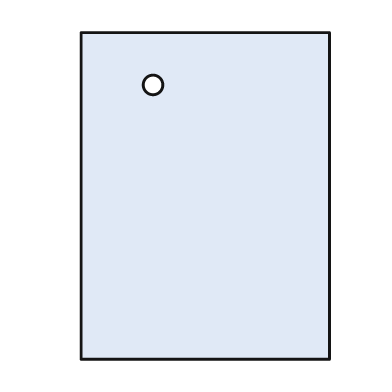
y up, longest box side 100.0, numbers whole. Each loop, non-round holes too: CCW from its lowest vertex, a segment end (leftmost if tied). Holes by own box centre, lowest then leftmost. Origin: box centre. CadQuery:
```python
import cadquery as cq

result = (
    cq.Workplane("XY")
    .moveTo(-38.0, -50.0)
    .lineTo(38.0, -50.0)
    .lineTo(38.0, 50.0)
    .lineTo(-38.0, 50.0)
    .close()
    .moveTo(-16.0, 34.0)
    .circle(3.0)
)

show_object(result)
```